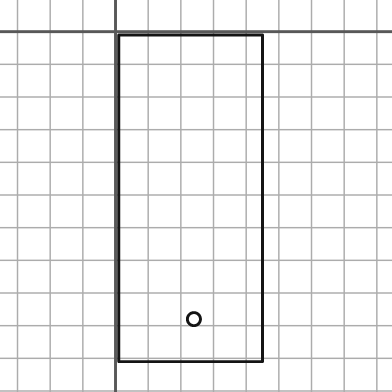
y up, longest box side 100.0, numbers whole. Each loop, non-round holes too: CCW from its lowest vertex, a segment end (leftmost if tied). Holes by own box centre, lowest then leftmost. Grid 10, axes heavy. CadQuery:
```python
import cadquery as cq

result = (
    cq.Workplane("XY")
    .moveTo(1.0, -101.0)
    .lineTo(45.0, -101.0)
    .lineTo(45.0, -1.0)
    .lineTo(1.0, -1.0)
    .close()
    .moveTo(24.0, -88.0)
    .circle(2.0)
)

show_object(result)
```